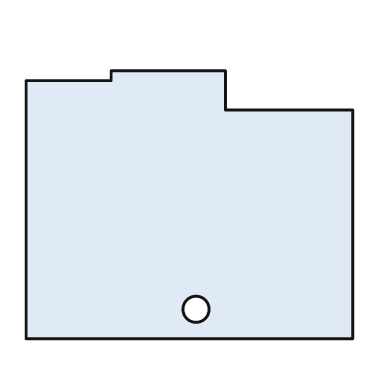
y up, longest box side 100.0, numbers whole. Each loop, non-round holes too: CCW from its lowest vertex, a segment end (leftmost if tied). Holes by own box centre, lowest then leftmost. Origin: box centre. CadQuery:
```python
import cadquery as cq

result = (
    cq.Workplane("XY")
    .moveTo(-50.0, -41.0)
    .lineTo(50.0, -41.0)
    .lineTo(50.0, 29.0)
    .lineTo(11.0, 29.0)
    .lineTo(11.0, 41.0)
    .lineTo(-24.0, 41.0)
    .lineTo(-24.0, 38.0)
    .lineTo(-50.0, 38.0)
    .close()
    .moveTo(2.0, -32.0)
    .circle(4.0)
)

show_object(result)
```